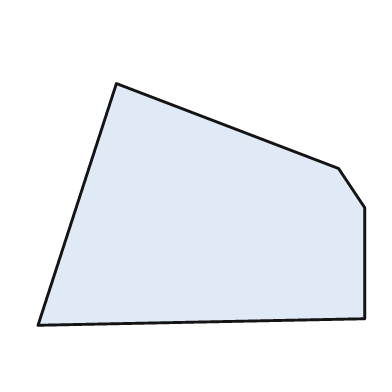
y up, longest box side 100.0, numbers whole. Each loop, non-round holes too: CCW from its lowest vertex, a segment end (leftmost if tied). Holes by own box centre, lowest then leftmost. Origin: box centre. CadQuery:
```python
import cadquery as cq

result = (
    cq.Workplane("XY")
    .moveTo(-50.0, -37.0)
    .lineTo(50.0, -35.0)
    .lineTo(50.0, -1.0)
    .lineTo(42.0, 11.0)
    .lineTo(-26.0, 37.0)
    .close()
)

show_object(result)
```